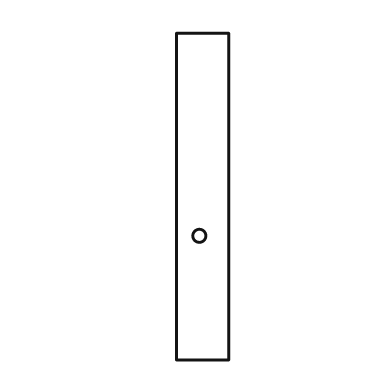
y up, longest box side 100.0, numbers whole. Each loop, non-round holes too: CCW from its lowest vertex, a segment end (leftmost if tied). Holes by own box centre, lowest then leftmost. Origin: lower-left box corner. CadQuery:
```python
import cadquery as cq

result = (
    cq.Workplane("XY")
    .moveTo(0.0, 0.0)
    .lineTo(16.0, 0.0)
    .lineTo(16.0, 100.0)
    .lineTo(0.0, 100.0)
    .close()
    .moveTo(7.0, 38.0)
    .circle(2.0)
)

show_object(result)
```